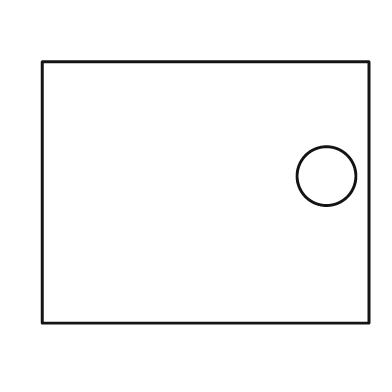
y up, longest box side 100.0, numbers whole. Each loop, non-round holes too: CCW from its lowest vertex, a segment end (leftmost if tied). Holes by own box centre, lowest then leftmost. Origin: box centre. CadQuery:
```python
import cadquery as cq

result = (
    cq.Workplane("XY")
    .moveTo(-50.0, -40.0)
    .lineTo(50.0, -40.0)
    .lineTo(50.0, 40.0)
    .lineTo(-50.0, 40.0)
    .close()
    .moveTo(37.0, 5.0)
    .circle(9.0)
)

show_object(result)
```